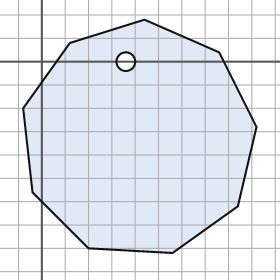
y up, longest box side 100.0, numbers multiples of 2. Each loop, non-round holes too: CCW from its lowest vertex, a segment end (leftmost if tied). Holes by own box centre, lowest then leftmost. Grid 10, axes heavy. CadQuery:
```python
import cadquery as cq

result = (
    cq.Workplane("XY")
    .moveTo(56.0, -82.0)
    .lineTo(84.0, -62.0)
    .lineTo(92.0, -28.0)
    .lineTo(76.0, 4.0)
    .lineTo(44.0, 18.0)
    .lineTo(12.0, 8.0)
    .lineTo(-8.0, -20.0)
    .lineTo(-4.0, -56.0)
    .lineTo(20.0, -80.0)
    .close()
    .moveTo(36.0, 0.0)
    .circle(4.0)
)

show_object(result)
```